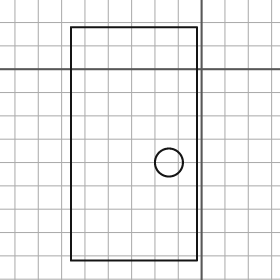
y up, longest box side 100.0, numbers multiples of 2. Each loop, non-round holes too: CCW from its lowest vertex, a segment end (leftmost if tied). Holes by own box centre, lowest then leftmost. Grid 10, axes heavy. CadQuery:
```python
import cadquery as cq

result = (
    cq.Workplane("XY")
    .moveTo(-56.0, -82.0)
    .lineTo(-2.0, -82.0)
    .lineTo(-2.0, 18.0)
    .lineTo(-56.0, 18.0)
    .close()
    .moveTo(-14.0, -40.0)
    .circle(6.0)
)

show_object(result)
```